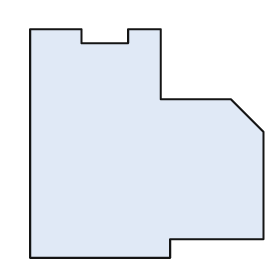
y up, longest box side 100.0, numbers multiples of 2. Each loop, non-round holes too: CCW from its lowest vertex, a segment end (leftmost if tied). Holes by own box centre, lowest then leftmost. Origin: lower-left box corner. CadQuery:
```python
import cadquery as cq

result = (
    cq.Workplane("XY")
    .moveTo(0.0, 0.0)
    .lineTo(60.0, 0.0)
    .lineTo(60.0, 8.0)
    .lineTo(100.0, 8.0)
    .lineTo(100.0, 54.0)
    .lineTo(86.0, 68.0)
    .lineTo(56.0, 68.0)
    .lineTo(56.0, 98.0)
    .lineTo(42.0, 98.0)
    .lineTo(42.0, 92.0)
    .lineTo(22.0, 92.0)
    .lineTo(22.0, 98.0)
    .lineTo(0.0, 98.0)
    .close()
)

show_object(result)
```